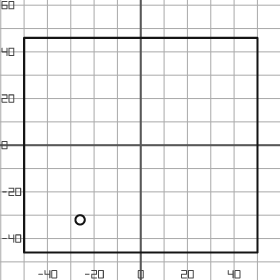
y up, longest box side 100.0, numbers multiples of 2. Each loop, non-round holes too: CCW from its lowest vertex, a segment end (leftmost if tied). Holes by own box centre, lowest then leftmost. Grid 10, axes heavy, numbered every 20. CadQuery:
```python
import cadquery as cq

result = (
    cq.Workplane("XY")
    .moveTo(-50.0, -46.0)
    .lineTo(50.0, -46.0)
    .lineTo(50.0, 46.0)
    .lineTo(-50.0, 46.0)
    .close()
    .moveTo(-26.0, -32.0)
    .circle(2.0)
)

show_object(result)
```